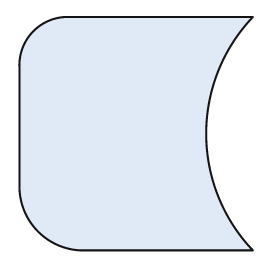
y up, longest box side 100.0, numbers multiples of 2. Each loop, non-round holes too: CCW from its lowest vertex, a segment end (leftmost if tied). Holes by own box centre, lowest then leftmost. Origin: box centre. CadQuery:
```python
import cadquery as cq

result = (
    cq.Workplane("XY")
    .moveTo(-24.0, -50.0)
    .lineTo(50.0, -50.0)
    .threePointArc((30.0, 0.0), (50.0, 50.0))
    .lineTo(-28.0, 50.0)
    .threePointArc((-44.0, 44.0), (-50.0, 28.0))
    .lineTo(-50.0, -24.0)
    .threePointArc((-42.0, -42.0), (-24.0, -50.0))
    .close()
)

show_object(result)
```